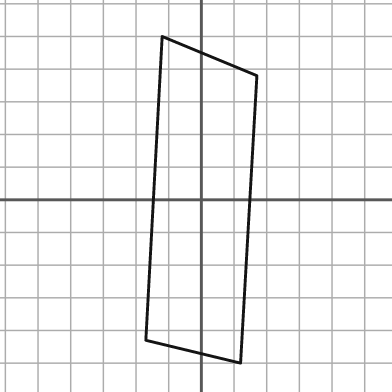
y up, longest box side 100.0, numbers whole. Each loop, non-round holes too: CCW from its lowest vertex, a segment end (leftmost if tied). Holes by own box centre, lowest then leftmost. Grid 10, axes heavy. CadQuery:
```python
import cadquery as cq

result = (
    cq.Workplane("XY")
    .moveTo(12.0, -50.0)
    .lineTo(17.0, 38.0)
    .lineTo(-12.0, 50.0)
    .lineTo(-17.0, -43.0)
    .close()
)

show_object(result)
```